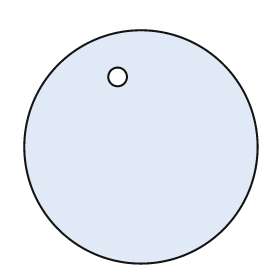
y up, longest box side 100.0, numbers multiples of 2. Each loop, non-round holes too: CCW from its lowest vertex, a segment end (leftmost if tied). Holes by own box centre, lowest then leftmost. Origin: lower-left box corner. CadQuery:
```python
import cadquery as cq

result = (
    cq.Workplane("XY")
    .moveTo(50.0, 50.0)
    .circle(50.0)
    .moveTo(40.0, 80.0)
    .circle(4.0)
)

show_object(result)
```